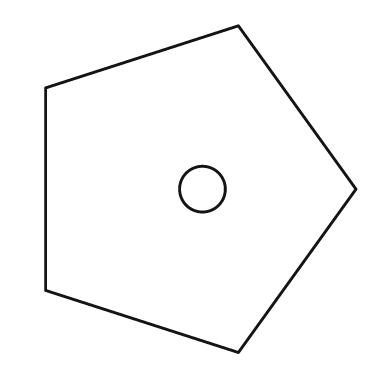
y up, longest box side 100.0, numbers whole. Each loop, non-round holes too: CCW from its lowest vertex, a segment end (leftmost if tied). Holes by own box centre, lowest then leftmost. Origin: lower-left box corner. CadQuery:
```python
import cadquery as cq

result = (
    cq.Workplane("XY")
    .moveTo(59.0, 0.0)
    .lineTo(95.0, 50.0)
    .lineTo(59.0, 100.0)
    .lineTo(0.0, 81.0)
    .lineTo(0.0, 19.0)
    .close()
    .moveTo(48.0, 50.0)
    .circle(7.0)
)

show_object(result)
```